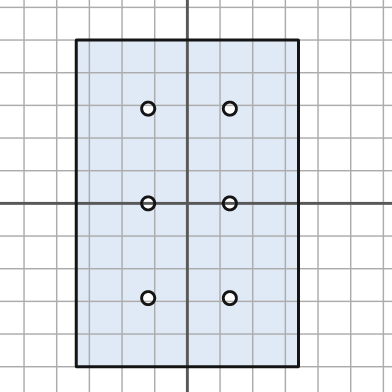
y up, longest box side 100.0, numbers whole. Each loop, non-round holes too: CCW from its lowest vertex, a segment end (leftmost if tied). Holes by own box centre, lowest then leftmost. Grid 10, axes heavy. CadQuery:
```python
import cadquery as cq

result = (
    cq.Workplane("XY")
    .moveTo(-34.0, -50.0)
    .lineTo(34.0, -50.0)
    .lineTo(34.0, 50.0)
    .lineTo(-34.0, 50.0)
    .close()
    .moveTo(-12.0, -29.0)
    .circle(2.0)
    .moveTo(13.0, -29.0)
    .circle(2.0)
    .moveTo(-12.0, 0.0)
    .circle(2.0)
    .moveTo(13.0, 0.0)
    .circle(2.0)
    .moveTo(-12.0, 29.0)
    .circle(2.0)
    .moveTo(13.0, 29.0)
    .circle(2.0)
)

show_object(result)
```